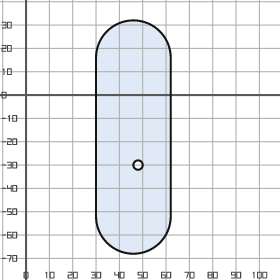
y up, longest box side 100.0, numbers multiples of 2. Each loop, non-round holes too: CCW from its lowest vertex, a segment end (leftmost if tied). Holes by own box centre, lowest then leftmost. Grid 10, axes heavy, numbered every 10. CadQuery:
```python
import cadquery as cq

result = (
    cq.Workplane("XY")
    .moveTo(30.0, -52.0)
    .threePointArc((46.0, -68.0), (62.0, -52.0))
    .lineTo(62.0, 16.0)
    .threePointArc((46.0, 32.0), (30.0, 16.0))
    .close()
    .moveTo(48.0, -30.0)
    .circle(2.0)
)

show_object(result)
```